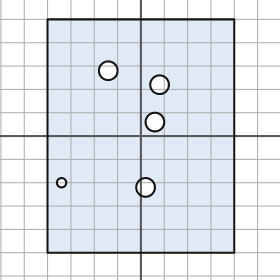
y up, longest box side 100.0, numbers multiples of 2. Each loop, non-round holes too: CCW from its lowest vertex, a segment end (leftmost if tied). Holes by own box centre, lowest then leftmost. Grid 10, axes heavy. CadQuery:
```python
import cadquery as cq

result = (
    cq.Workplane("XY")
    .moveTo(-40.0, -50.0)
    .lineTo(40.0, -50.0)
    .lineTo(40.0, 50.0)
    .lineTo(-40.0, 50.0)
    .close()
    .moveTo(2.0, -22.0)
    .circle(4.0)
    .moveTo(-34.0, -20.0)
    .circle(2.0)
    .moveTo(6.0, 6.0)
    .circle(4.0)
    .moveTo(8.0, 22.0)
    .circle(4.0)
    .moveTo(-14.0, 28.0)
    .circle(4.0)
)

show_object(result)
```